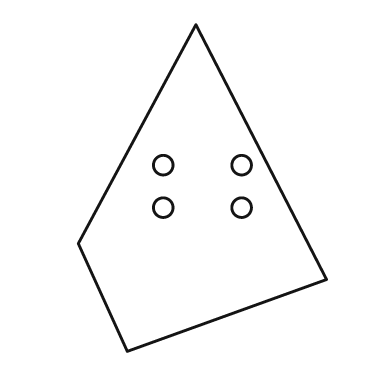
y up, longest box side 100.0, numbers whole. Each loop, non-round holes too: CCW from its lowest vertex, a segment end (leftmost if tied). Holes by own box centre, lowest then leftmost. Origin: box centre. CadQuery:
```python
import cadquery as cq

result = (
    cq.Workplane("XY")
    .moveTo(-23.0, -50.0)
    .lineTo(38.0, -28.0)
    .lineTo(-2.0, 50.0)
    .lineTo(-38.0, -17.0)
    .close()
    .moveTo(-12.0, -6.0)
    .circle(3.0)
    .moveTo(12.0, -6.0)
    .circle(3.0)
    .moveTo(-12.0, 7.0)
    .circle(3.0)
    .moveTo(12.0, 7.0)
    .circle(3.0)
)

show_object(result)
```